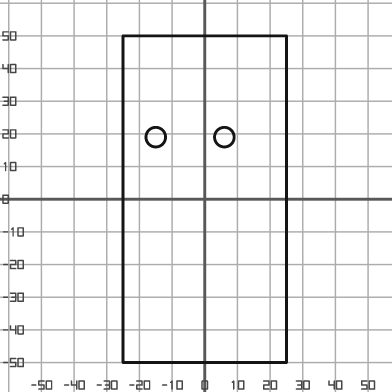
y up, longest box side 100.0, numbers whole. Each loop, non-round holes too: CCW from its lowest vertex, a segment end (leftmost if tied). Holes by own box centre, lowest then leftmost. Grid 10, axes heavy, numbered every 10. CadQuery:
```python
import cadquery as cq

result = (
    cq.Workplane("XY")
    .moveTo(-25.0, -50.0)
    .lineTo(25.0, -50.0)
    .lineTo(25.0, 50.0)
    .lineTo(-25.0, 50.0)
    .close()
    .moveTo(-15.0, 19.0)
    .circle(3.0)
    .moveTo(6.0, 19.0)
    .circle(3.0)
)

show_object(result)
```